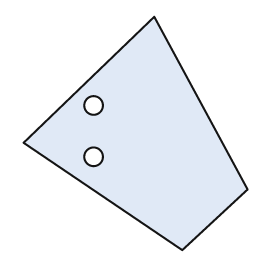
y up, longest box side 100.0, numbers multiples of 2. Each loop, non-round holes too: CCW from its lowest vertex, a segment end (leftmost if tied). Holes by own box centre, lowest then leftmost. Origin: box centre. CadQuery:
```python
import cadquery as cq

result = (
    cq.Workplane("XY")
    .moveTo(20.0, -50.0)
    .lineTo(48.0, -24.0)
    .lineTo(8.0, 50.0)
    .lineTo(-48.0, -4.0)
    .close()
    .moveTo(-18.0, -10.0)
    .circle(4.0)
    .moveTo(-18.0, 12.0)
    .circle(4.0)
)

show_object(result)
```